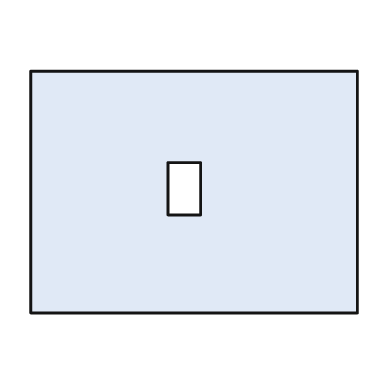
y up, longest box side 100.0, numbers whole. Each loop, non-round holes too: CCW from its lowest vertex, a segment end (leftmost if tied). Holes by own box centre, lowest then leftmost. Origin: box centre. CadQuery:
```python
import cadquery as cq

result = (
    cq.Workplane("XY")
    .moveTo(-50.0, -37.0)
    .lineTo(50.0, -37.0)
    .lineTo(50.0, 37.0)
    .lineTo(-50.0, 37.0)
    .close()
    .moveTo(-8.0, -7.0)
    .lineTo(2.0, -7.0)
    .lineTo(2.0, 9.0)
    .lineTo(-8.0, 9.0)
    .close()
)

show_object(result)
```